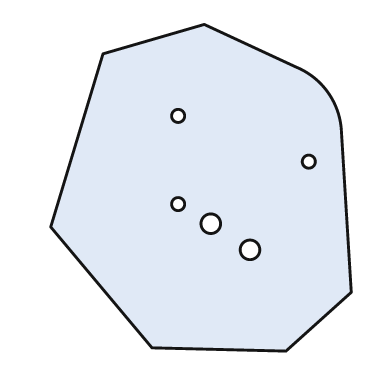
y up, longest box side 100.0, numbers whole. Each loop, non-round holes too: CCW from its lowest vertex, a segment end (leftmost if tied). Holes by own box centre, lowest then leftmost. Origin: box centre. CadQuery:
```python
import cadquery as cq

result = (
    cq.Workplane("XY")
    .moveTo(26.0, -50.0)
    .lineTo(46.0, -32.0)
    .lineTo(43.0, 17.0)
    .threePointArc((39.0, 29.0), (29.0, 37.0))
    .lineTo(1.0, 50.0)
    .lineTo(-30.0, 41.0)
    .lineTo(-46.0, -12.0)
    .lineTo(-15.0, -49.0)
    .close()
    .moveTo(15.0, -19.0)
    .circle(3.0)
    .moveTo(3.0, -11.0)
    .circle(3.0)
    .moveTo(-7.0, -5.0)
    .circle(2.0)
    .moveTo(33.0, 8.0)
    .circle(2.0)
    .moveTo(-7.0, 22.0)
    .circle(2.0)
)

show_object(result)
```